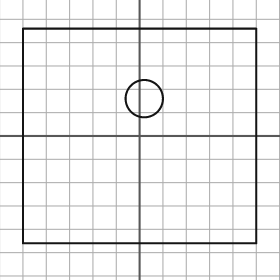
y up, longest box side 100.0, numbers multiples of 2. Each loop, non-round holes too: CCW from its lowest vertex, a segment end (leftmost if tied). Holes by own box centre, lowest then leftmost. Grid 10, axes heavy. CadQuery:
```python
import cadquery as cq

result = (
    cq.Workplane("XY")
    .moveTo(-50.0, -46.0)
    .lineTo(50.0, -46.0)
    .lineTo(50.0, 46.0)
    .lineTo(-50.0, 46.0)
    .close()
    .moveTo(2.0, 16.0)
    .circle(8.0)
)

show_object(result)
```